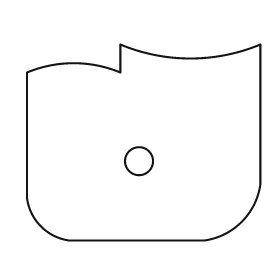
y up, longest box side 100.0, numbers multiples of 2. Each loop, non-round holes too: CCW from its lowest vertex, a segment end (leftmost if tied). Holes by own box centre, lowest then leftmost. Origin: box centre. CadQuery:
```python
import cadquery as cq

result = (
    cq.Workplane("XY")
    .moveTo(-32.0, -42.0)
    .lineTo(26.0, -42.0)
    .threePointArc((42.0, -34.0), (50.0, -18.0))
    .lineTo(50.0, 42.0)
    .threePointArc((20.0, 36.0), (-10.0, 42.0))
    .lineTo(-10.0, 30.0)
    .threePointArc((-30.0, 34.0), (-50.0, 30.0))
    .lineTo(-50.0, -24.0)
    .threePointArc((-44.0, -36.0), (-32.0, -42.0))
    .close()
    .moveTo(-2.0, -8.0)
    .circle(6.0)
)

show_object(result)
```